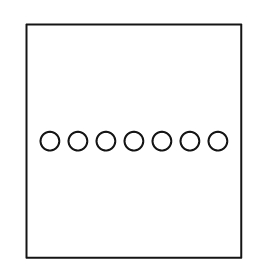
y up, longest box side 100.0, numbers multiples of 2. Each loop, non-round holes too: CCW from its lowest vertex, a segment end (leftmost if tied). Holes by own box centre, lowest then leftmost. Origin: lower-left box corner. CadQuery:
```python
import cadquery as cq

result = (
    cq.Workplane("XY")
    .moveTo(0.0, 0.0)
    .lineTo(92.0, 0.0)
    .lineTo(92.0, 100.0)
    .lineTo(0.0, 100.0)
    .close()
    .moveTo(10.0, 50.0)
    .circle(4.0)
    .moveTo(22.0, 50.0)
    .circle(4.0)
    .moveTo(34.0, 50.0)
    .circle(4.0)
    .moveTo(46.0, 50.0)
    .circle(4.0)
    .moveTo(58.0, 50.0)
    .circle(4.0)
    .moveTo(70.0, 50.0)
    .circle(4.0)
    .moveTo(82.0, 50.0)
    .circle(4.0)
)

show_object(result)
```